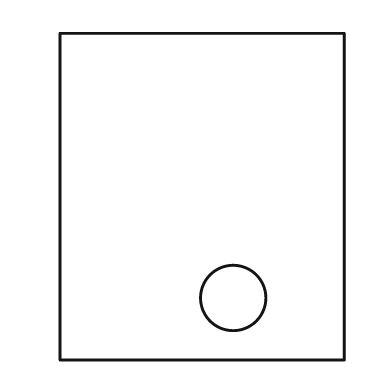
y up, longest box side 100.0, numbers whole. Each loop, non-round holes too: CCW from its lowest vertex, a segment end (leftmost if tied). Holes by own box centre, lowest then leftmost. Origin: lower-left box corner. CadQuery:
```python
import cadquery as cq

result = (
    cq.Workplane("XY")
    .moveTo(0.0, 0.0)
    .lineTo(87.0, 0.0)
    .lineTo(87.0, 100.0)
    .lineTo(0.0, 100.0)
    .close()
    .moveTo(53.0, 19.0)
    .circle(10.0)
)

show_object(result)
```